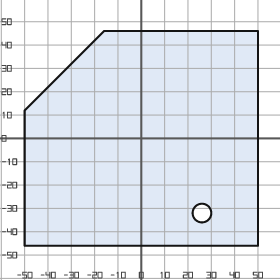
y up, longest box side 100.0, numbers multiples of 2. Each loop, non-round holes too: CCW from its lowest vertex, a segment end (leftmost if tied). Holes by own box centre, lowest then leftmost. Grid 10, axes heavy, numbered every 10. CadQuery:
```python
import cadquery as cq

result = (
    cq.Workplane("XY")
    .moveTo(-50.0, -46.0)
    .lineTo(50.0, -46.0)
    .lineTo(50.0, 46.0)
    .lineTo(-16.0, 46.0)
    .lineTo(-50.0, 12.0)
    .close()
    .moveTo(26.0, -32.0)
    .circle(4.0)
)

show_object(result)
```